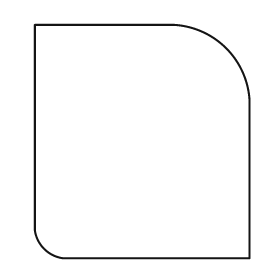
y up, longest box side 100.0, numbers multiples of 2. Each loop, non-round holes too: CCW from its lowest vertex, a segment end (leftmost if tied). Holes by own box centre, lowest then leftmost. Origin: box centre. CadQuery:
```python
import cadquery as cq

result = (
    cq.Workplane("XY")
    .moveTo(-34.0, -50.0)
    .lineTo(46.0, -50.0)
    .lineTo(46.0, 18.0)
    .threePointArc((36.0, 40.0), (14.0, 50.0))
    .lineTo(-46.0, 50.0)
    .lineTo(-46.0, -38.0)
    .threePointArc((-42.0, -46.0), (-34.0, -50.0))
    .close()
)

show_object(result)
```